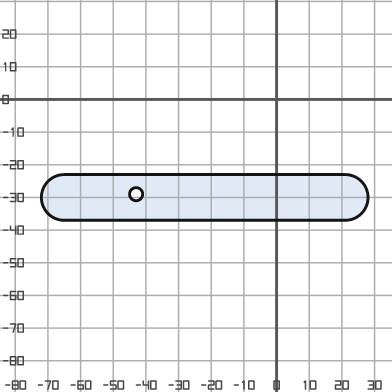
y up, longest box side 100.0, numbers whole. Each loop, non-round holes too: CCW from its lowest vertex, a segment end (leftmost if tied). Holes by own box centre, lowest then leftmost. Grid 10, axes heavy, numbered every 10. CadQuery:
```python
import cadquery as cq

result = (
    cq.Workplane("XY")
    .moveTo(-65.0, -37.0)
    .lineTo(21.0, -37.0)
    .threePointArc((28.0, -30.0), (21.0, -23.0))
    .lineTo(-65.0, -23.0)
    .threePointArc((-72.0, -30.0), (-65.0, -37.0))
    .close()
    .moveTo(-43.0, -29.0)
    .circle(2.0)
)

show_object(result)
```